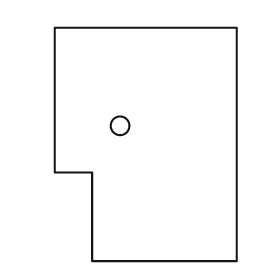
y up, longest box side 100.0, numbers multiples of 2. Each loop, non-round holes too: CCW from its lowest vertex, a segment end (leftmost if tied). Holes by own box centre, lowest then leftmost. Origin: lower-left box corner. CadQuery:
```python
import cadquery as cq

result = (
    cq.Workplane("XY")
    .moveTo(16.0, 0.0)
    .lineTo(78.0, 0.0)
    .lineTo(78.0, 100.0)
    .lineTo(0.0, 100.0)
    .lineTo(0.0, 38.0)
    .lineTo(16.0, 38.0)
    .close()
    .moveTo(28.0, 58.0)
    .circle(4.0)
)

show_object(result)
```